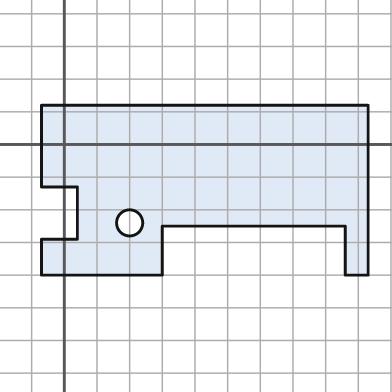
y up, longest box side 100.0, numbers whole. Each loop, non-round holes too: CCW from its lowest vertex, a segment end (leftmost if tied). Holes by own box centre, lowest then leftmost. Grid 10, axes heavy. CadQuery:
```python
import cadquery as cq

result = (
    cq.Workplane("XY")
    .moveTo(-7.0, -40.0)
    .lineTo(30.0, -40.0)
    .lineTo(30.0, -25.0)
    .lineTo(86.0, -25.0)
    .lineTo(86.0, -40.0)
    .lineTo(93.0, -40.0)
    .lineTo(93.0, 12.0)
    .lineTo(-7.0, 12.0)
    .lineTo(-7.0, -13.0)
    .lineTo(4.0, -13.0)
    .lineTo(4.0, -29.0)
    .lineTo(-7.0, -29.0)
    .close()
    .moveTo(20.0, -24.0)
    .circle(4.0)
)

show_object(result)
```